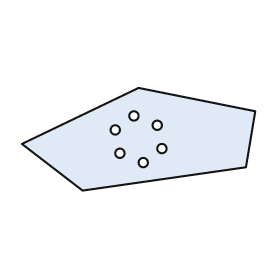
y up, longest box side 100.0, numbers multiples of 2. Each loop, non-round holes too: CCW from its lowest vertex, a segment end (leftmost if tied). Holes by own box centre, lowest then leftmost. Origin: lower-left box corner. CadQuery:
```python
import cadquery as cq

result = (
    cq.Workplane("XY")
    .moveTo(26.0, 0.0)
    .lineTo(96.0, 10.0)
    .lineTo(100.0, 34.0)
    .lineTo(50.0, 44.0)
    .lineTo(0.0, 20.0)
    .close()
    .moveTo(52.0, 12.0)
    .circle(2.0)
    .moveTo(42.0, 16.0)
    .circle(2.0)
    .moveTo(60.0, 18.0)
    .circle(2.0)
    .moveTo(40.0, 26.0)
    .circle(2.0)
    .moveTo(58.0, 28.0)
    .circle(2.0)
    .moveTo(48.0, 32.0)
    .circle(2.0)
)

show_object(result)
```